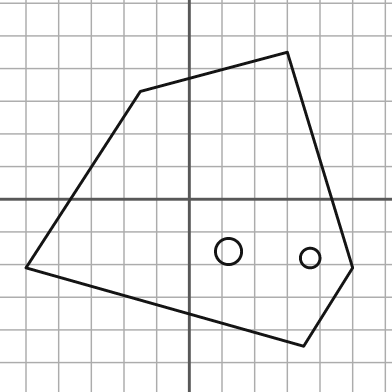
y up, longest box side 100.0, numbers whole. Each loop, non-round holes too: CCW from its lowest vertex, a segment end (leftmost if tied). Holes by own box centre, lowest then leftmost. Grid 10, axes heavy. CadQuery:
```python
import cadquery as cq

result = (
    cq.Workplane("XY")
    .moveTo(35.0, -45.0)
    .lineTo(50.0, -21.0)
    .lineTo(30.0, 45.0)
    .lineTo(-15.0, 33.0)
    .lineTo(-50.0, -21.0)
    .close()
    .moveTo(37.0, -18.0)
    .circle(3.0)
    .moveTo(12.0, -16.0)
    .circle(4.0)
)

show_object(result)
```